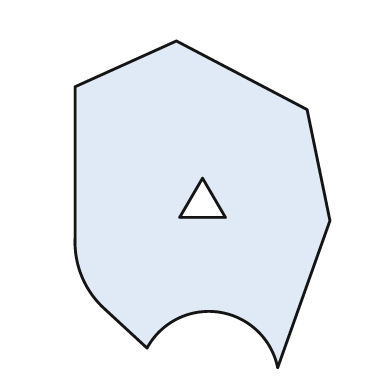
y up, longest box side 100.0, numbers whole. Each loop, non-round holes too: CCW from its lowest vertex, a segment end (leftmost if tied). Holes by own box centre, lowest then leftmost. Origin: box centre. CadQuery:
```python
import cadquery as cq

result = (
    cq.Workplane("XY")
    .moveTo(23.0, -50.0)
    .lineTo(39.0, -5.0)
    .lineTo(32.0, 29.0)
    .lineTo(-8.0, 50.0)
    .lineTo(-39.0, 36.0)
    .lineTo(-39.0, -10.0)
    .threePointArc((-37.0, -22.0), (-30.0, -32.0))
    .lineTo(-17.0, -44.0)
    .threePointArc((5.0, -33.0), (23.0, -50.0))
    .close()
    .moveTo(-7.0, -4.0)
    .lineTo(7.0, -4.0)
    .lineTo(0.0, 8.0)
    .close()
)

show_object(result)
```